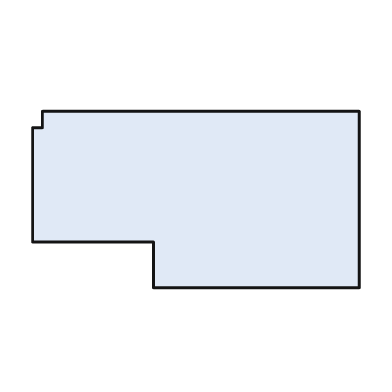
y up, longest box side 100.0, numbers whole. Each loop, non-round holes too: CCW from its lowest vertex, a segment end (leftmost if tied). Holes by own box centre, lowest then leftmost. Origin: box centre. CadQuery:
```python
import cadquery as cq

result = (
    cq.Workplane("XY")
    .moveTo(-13.0, -27.0)
    .lineTo(50.0, -27.0)
    .lineTo(50.0, 27.0)
    .lineTo(-47.0, 27.0)
    .lineTo(-47.0, 22.0)
    .lineTo(-50.0, 22.0)
    .lineTo(-50.0, -13.0)
    .lineTo(-13.0, -13.0)
    .close()
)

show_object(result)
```